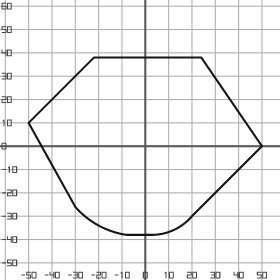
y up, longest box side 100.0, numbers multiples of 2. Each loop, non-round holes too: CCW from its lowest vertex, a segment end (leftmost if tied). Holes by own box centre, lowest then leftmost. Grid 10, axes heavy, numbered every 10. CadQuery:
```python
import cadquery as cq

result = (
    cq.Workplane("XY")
    .moveTo(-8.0, -38.0)
    .lineTo(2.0, -38.0)
    .threePointArc((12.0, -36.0), (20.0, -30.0))
    .lineTo(50.0, 0.0)
    .lineTo(24.0, 38.0)
    .lineTo(-22.0, 38.0)
    .lineTo(-50.0, 10.0)
    .lineTo(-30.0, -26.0)
    .threePointArc((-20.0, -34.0), (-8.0, -38.0))
    .close()
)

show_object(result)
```